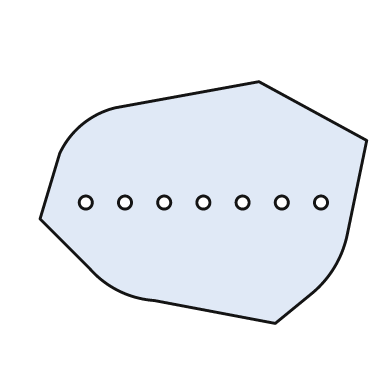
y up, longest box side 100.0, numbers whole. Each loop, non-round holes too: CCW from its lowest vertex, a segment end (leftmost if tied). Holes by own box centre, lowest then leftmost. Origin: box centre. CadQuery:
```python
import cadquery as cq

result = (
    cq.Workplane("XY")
    .moveTo(22.0, -37.0)
    .lineTo(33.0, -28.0)
    .threePointArc((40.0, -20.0), (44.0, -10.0))
    .lineTo(50.0, 19.0)
    .lineTo(17.0, 37.0)
    .lineTo(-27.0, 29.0)
    .threePointArc((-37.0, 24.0), (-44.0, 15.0))
    .lineTo(-50.0, -5.0)
    .lineTo(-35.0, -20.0)
    .threePointArc((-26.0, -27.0), (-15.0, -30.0))
    .close()
    .moveTo(-36.0, 0.0)
    .circle(2.0)
    .moveTo(-24.0, 0.0)
    .circle(2.0)
    .moveTo(-12.0, 0.0)
    .circle(2.0)
    .moveTo(0.0, 0.0)
    .circle(2.0)
    .moveTo(12.0, 0.0)
    .circle(2.0)
    .moveTo(24.0, 0.0)
    .circle(2.0)
    .moveTo(36.0, 0.0)
    .circle(2.0)
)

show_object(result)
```